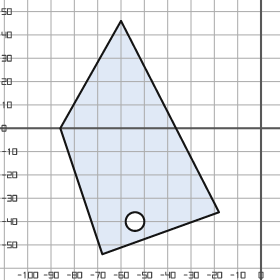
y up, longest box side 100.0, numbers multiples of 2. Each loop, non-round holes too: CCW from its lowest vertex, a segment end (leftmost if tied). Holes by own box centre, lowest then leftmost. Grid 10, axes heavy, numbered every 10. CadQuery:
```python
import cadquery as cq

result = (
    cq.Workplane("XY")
    .moveTo(-68.0, -54.0)
    .lineTo(-18.0, -36.0)
    .lineTo(-60.0, 46.0)
    .lineTo(-86.0, 0.0)
    .close()
    .moveTo(-54.0, -40.0)
    .circle(4.0)
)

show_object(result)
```